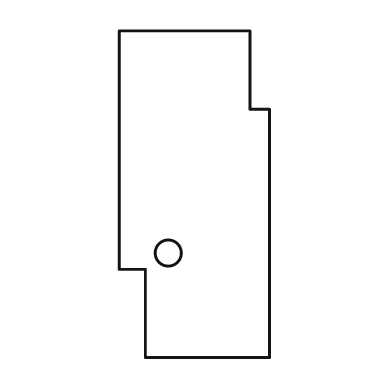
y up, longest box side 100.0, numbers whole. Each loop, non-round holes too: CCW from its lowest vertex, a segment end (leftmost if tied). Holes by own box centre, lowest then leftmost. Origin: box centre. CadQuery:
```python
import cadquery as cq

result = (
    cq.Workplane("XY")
    .moveTo(-15.0, -50.0)
    .lineTo(23.0, -50.0)
    .lineTo(23.0, 26.0)
    .lineTo(17.0, 26.0)
    .lineTo(17.0, 50.0)
    .lineTo(-23.0, 50.0)
    .lineTo(-23.0, -23.0)
    .lineTo(-15.0, -23.0)
    .close()
    .moveTo(-8.0, -18.0)
    .circle(4.0)
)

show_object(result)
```